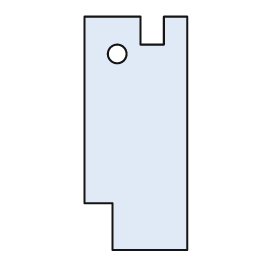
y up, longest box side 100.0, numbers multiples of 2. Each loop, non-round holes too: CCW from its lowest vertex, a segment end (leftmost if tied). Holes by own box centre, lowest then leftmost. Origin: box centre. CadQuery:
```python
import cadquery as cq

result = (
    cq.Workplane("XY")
    .moveTo(-10.0, -50.0)
    .lineTo(22.0, -50.0)
    .lineTo(22.0, 50.0)
    .lineTo(12.0, 50.0)
    .lineTo(12.0, 38.0)
    .lineTo(2.0, 38.0)
    .lineTo(2.0, 50.0)
    .lineTo(-22.0, 50.0)
    .lineTo(-22.0, -30.0)
    .lineTo(-10.0, -30.0)
    .close()
    .moveTo(-8.0, 34.0)
    .circle(4.0)
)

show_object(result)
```